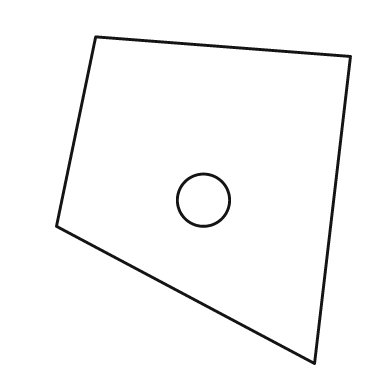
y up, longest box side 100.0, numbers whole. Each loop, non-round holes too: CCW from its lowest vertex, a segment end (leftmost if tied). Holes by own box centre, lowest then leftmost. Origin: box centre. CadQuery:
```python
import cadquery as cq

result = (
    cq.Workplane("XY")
    .moveTo(34.0, -50.0)
    .lineTo(45.0, 44.0)
    .lineTo(-33.0, 50.0)
    .lineTo(-45.0, -8.0)
    .close()
    .moveTo(0.0, 0.0)
    .circle(8.0)
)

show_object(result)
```